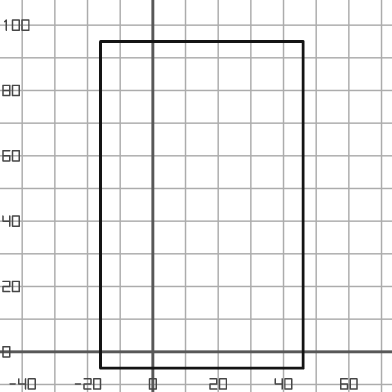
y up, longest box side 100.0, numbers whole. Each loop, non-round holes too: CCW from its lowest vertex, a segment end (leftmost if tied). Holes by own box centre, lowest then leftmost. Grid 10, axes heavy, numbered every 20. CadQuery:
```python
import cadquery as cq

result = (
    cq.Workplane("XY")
    .moveTo(-16.0, -5.0)
    .lineTo(46.0, -5.0)
    .lineTo(46.0, 95.0)
    .lineTo(-16.0, 95.0)
    .close()
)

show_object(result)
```